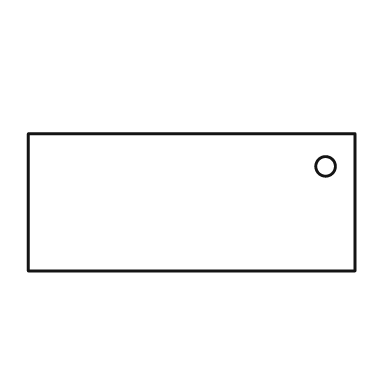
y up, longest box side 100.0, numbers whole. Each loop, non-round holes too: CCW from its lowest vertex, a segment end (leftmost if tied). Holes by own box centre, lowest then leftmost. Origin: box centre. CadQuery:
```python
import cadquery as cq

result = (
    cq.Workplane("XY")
    .moveTo(-50.0, -21.0)
    .lineTo(50.0, -21.0)
    .lineTo(50.0, 21.0)
    .lineTo(-50.0, 21.0)
    .close()
    .moveTo(41.0, 11.0)
    .circle(3.0)
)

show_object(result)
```